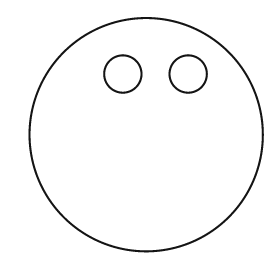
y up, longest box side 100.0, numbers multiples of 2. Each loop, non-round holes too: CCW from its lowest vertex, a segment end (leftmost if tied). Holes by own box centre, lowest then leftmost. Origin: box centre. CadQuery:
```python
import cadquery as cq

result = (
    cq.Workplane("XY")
    .moveTo(0.0, 0.0)
    .circle(50.0)
    .moveTo(-10.0, 26.0)
    .circle(8.0)
    .moveTo(18.0, 26.0)
    .circle(8.0)
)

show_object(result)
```